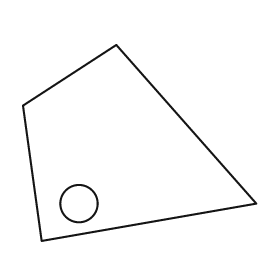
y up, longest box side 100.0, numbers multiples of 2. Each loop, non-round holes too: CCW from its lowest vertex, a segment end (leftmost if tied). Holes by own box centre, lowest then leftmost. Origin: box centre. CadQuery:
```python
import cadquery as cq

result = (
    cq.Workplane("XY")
    .moveTo(-42.0, -42.0)
    .lineTo(50.0, -26.0)
    .lineTo(-10.0, 42.0)
    .lineTo(-50.0, 16.0)
    .close()
    .moveTo(-26.0, -26.0)
    .circle(8.0)
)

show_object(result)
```